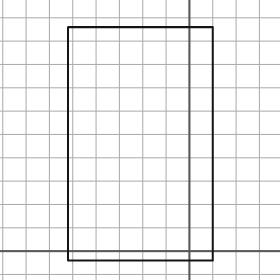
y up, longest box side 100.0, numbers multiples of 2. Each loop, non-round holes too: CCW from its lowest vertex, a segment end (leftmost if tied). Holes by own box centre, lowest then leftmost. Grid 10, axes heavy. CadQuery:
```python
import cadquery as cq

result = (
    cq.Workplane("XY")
    .moveTo(-52.0, -4.0)
    .lineTo(10.0, -4.0)
    .lineTo(10.0, 96.0)
    .lineTo(-52.0, 96.0)
    .close()
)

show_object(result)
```